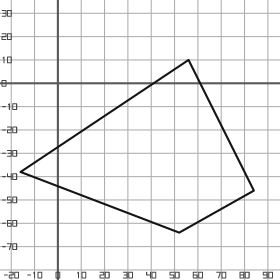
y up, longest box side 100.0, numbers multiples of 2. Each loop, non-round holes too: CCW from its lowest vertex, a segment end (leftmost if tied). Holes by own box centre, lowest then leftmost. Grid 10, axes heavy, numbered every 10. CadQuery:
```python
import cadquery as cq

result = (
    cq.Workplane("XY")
    .moveTo(52.0, -64.0)
    .lineTo(84.0, -46.0)
    .lineTo(56.0, 10.0)
    .lineTo(-16.0, -38.0)
    .close()
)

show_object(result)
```